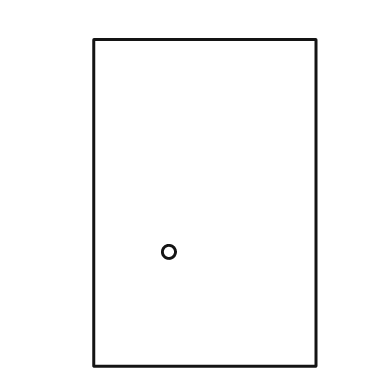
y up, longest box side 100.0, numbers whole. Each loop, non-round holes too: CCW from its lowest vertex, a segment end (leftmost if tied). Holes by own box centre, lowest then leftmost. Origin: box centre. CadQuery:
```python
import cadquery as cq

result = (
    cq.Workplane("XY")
    .moveTo(-34.0, -50.0)
    .lineTo(34.0, -50.0)
    .lineTo(34.0, 50.0)
    .lineTo(-34.0, 50.0)
    .close()
    .moveTo(-11.0, -15.0)
    .circle(2.0)
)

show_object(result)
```